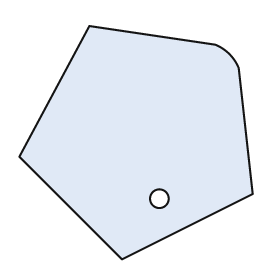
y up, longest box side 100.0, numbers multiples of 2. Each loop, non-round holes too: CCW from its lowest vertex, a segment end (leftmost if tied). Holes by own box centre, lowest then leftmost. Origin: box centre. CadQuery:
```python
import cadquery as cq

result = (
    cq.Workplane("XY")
    .moveTo(-6.0, -50.0)
    .lineTo(50.0, -22.0)
    .lineTo(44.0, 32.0)
    .threePointArc((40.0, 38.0), (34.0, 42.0))
    .lineTo(-20.0, 50.0)
    .lineTo(-50.0, -6.0)
    .close()
    .moveTo(10.0, -24.0)
    .circle(4.0)
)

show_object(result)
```